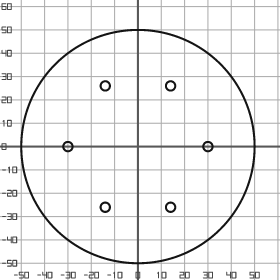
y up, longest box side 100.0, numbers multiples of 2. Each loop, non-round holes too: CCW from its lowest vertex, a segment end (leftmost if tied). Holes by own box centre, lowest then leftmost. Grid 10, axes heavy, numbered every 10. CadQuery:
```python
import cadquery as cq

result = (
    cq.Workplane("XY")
    .moveTo(0.0, 0.0)
    .circle(50.0)
    .moveTo(-14.0, -26.0)
    .circle(2.0)
    .moveTo(14.0, -26.0)
    .circle(2.0)
    .moveTo(-30.0, 0.0)
    .circle(2.0)
    .moveTo(30.0, 0.0)
    .circle(2.0)
    .moveTo(-14.0, 26.0)
    .circle(2.0)
    .moveTo(14.0, 26.0)
    .circle(2.0)
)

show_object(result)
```